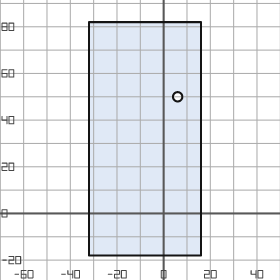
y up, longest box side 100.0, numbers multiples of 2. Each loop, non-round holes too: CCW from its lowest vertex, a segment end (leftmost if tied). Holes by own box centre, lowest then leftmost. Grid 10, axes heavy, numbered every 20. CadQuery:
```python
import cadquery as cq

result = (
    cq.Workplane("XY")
    .moveTo(-32.0, -18.0)
    .lineTo(16.0, -18.0)
    .lineTo(16.0, 82.0)
    .lineTo(-32.0, 82.0)
    .close()
    .moveTo(6.0, 50.0)
    .circle(2.0)
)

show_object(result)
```